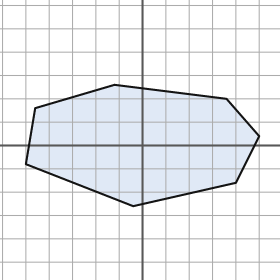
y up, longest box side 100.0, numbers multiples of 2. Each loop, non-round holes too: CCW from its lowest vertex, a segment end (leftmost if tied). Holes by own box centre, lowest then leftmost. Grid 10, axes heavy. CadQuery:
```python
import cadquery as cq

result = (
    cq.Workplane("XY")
    .moveTo(-4.0, -26.0)
    .lineTo(40.0, -16.0)
    .lineTo(50.0, 4.0)
    .lineTo(36.0, 20.0)
    .lineTo(-12.0, 26.0)
    .lineTo(-46.0, 16.0)
    .lineTo(-50.0, -8.0)
    .close()
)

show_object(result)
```